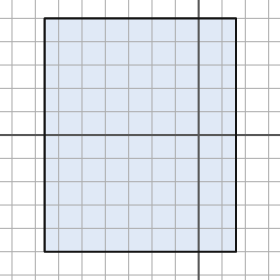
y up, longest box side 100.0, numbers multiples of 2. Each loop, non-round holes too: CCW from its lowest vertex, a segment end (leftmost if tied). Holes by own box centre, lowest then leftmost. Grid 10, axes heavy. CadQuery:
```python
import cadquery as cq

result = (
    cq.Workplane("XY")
    .moveTo(-66.0, -50.0)
    .lineTo(16.0, -50.0)
    .lineTo(16.0, 50.0)
    .lineTo(-66.0, 50.0)
    .close()
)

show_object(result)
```